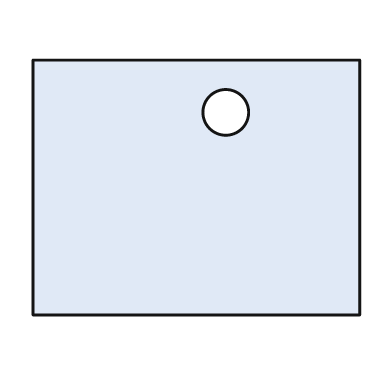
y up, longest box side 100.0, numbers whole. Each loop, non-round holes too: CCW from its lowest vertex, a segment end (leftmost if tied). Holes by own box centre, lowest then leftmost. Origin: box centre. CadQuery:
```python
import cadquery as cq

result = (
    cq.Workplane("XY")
    .moveTo(-50.0, -39.0)
    .lineTo(50.0, -39.0)
    .lineTo(50.0, 39.0)
    .lineTo(-50.0, 39.0)
    .close()
    .moveTo(9.0, 23.0)
    .circle(7.0)
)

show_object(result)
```